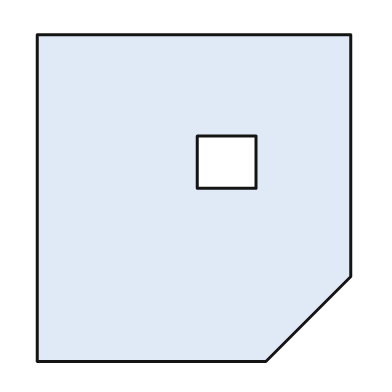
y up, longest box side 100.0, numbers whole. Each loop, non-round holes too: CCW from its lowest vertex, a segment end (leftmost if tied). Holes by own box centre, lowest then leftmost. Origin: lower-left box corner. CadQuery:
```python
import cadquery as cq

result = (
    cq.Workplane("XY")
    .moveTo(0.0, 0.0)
    .lineTo(70.0, 0.0)
    .lineTo(96.0, 26.0)
    .lineTo(96.0, 100.0)
    .lineTo(0.0, 100.0)
    .close()
    .moveTo(49.0, 53.0)
    .lineTo(67.0, 53.0)
    .lineTo(67.0, 69.0)
    .lineTo(49.0, 69.0)
    .close()
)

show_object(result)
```